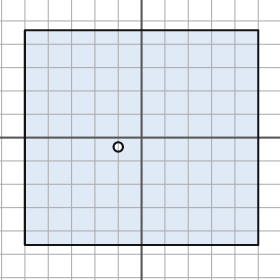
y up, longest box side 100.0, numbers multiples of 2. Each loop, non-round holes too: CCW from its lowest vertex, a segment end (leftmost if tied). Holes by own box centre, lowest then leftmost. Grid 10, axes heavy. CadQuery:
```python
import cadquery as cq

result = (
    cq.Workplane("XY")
    .moveTo(-50.0, -46.0)
    .lineTo(50.0, -46.0)
    .lineTo(50.0, 46.0)
    .lineTo(-50.0, 46.0)
    .close()
    .moveTo(-10.0, -4.0)
    .circle(2.0)
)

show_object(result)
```